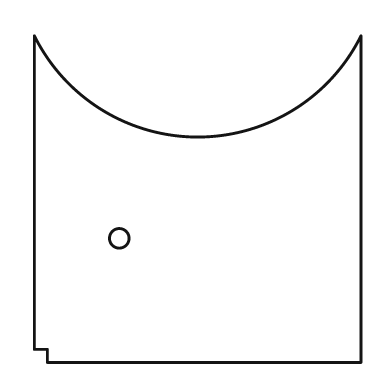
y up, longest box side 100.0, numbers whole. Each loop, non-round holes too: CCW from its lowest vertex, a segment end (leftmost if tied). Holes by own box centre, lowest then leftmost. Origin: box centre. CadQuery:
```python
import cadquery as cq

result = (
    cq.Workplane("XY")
    .moveTo(-46.0, -50.0)
    .lineTo(50.0, -50.0)
    .lineTo(50.0, 50.0)
    .threePointArc((0.0, 19.0), (-50.0, 50.0))
    .lineTo(-50.0, -46.0)
    .lineTo(-46.0, -46.0)
    .close()
    .moveTo(-24.0, -12.0)
    .circle(3.0)
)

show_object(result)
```